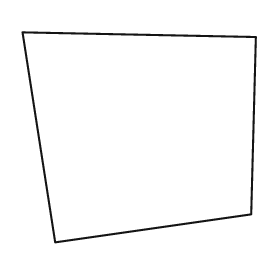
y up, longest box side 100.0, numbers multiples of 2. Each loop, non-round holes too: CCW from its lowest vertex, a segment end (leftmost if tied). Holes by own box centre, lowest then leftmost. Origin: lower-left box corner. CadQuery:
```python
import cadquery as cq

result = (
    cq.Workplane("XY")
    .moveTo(14.0, 0.0)
    .lineTo(98.0, 12.0)
    .lineTo(100.0, 88.0)
    .lineTo(0.0, 90.0)
    .close()
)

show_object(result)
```